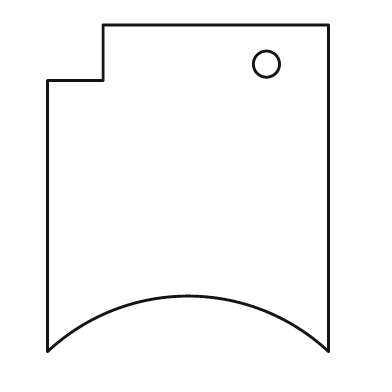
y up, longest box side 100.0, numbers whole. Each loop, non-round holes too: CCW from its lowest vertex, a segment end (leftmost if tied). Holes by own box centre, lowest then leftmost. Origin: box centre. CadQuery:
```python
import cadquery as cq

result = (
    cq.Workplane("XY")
    .moveTo(-43.0, -50.0)
    .threePointArc((0.0, -33.0), (43.0, -50.0))
    .lineTo(43.0, 50.0)
    .lineTo(-26.0, 50.0)
    .lineTo(-26.0, 33.0)
    .lineTo(-43.0, 33.0)
    .close()
    .moveTo(24.0, 38.0)
    .circle(4.0)
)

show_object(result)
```